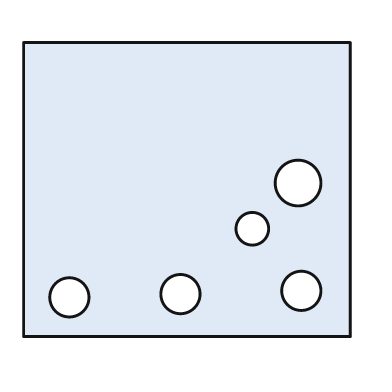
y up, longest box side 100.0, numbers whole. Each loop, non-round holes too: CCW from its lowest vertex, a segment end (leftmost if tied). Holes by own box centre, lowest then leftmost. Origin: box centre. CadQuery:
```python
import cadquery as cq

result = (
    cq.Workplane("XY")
    .moveTo(-50.0, -45.0)
    .lineTo(50.0, -45.0)
    .lineTo(50.0, 45.0)
    .lineTo(-50.0, 45.0)
    .close()
    .moveTo(-36.0, -33.0)
    .circle(6.0)
    .moveTo(-2.0, -32.0)
    .circle(6.0)
    .moveTo(35.0, -31.0)
    .circle(6.0)
    .moveTo(20.0, -12.0)
    .circle(5.0)
    .moveTo(34.0, 2.0)
    .circle(7.0)
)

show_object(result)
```